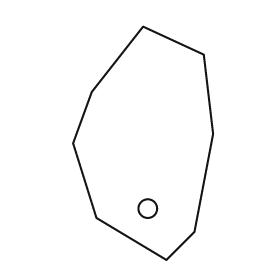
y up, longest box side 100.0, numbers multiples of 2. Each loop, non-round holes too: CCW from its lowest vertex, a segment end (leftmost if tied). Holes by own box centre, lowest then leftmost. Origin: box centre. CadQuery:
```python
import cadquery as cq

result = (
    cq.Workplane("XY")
    .moveTo(10.0, -50.0)
    .lineTo(22.0, -38.0)
    .lineTo(30.0, 4.0)
    .lineTo(26.0, 38.0)
    .lineTo(0.0, 50.0)
    .lineTo(-22.0, 22.0)
    .lineTo(-30.0, 0.0)
    .lineTo(-20.0, -32.0)
    .close()
    .moveTo(2.0, -28.0)
    .circle(4.0)
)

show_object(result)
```